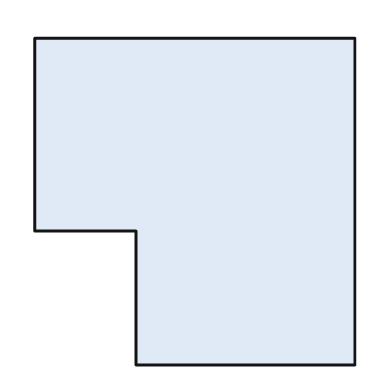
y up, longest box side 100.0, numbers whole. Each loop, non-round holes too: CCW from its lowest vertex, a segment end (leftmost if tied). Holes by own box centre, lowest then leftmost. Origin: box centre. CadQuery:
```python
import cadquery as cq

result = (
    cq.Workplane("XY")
    .moveTo(-18.0, -50.0)
    .lineTo(49.0, -50.0)
    .lineTo(49.0, 50.0)
    .lineTo(-49.0, 50.0)
    .lineTo(-49.0, -9.0)
    .lineTo(-18.0, -9.0)
    .close()
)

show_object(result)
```